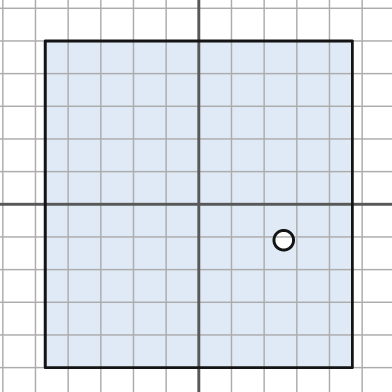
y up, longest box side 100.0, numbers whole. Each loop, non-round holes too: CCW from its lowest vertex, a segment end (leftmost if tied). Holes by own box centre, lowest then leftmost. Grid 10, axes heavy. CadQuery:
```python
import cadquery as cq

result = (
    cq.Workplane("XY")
    .moveTo(-47.0, -50.0)
    .lineTo(47.0, -50.0)
    .lineTo(47.0, 50.0)
    .lineTo(-47.0, 50.0)
    .close()
    .moveTo(26.0, -11.0)
    .circle(3.0)
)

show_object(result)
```